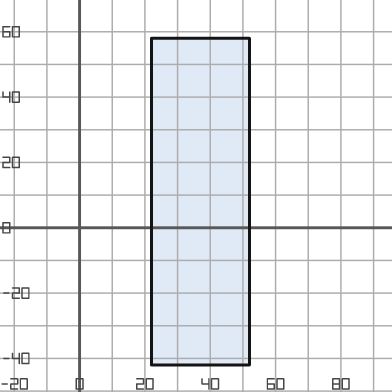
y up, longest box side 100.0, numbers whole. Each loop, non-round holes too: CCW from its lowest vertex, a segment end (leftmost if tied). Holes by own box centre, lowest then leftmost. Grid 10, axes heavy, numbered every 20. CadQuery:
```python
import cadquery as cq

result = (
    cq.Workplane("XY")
    .moveTo(22.0, -42.0)
    .lineTo(52.0, -42.0)
    .lineTo(52.0, 58.0)
    .lineTo(22.0, 58.0)
    .close()
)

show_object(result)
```